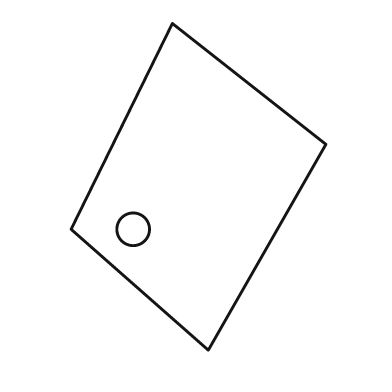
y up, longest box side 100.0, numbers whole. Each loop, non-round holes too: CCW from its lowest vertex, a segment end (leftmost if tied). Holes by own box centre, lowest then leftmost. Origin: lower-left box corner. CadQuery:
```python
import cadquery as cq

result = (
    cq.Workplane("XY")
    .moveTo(42.0, 0.0)
    .lineTo(78.0, 63.0)
    .lineTo(31.0, 100.0)
    .lineTo(0.0, 37.0)
    .close()
    .moveTo(19.0, 37.0)
    .circle(5.0)
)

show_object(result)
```